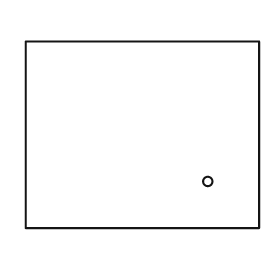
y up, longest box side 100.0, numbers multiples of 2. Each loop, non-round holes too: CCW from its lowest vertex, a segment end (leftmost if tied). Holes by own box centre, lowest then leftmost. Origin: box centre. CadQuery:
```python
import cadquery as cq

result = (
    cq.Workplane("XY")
    .moveTo(-50.0, -40.0)
    .lineTo(50.0, -40.0)
    .lineTo(50.0, 40.0)
    .lineTo(-50.0, 40.0)
    .close()
    .moveTo(28.0, -20.0)
    .circle(2.0)
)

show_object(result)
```